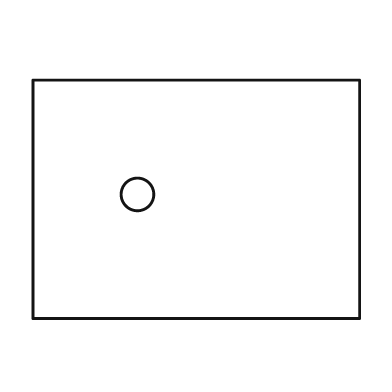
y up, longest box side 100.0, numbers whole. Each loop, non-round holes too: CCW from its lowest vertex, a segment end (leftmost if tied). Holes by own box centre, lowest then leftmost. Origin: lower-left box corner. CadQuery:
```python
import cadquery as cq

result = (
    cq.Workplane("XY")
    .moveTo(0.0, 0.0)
    .lineTo(100.0, 0.0)
    .lineTo(100.0, 73.0)
    .lineTo(0.0, 73.0)
    .close()
    .moveTo(32.0, 38.0)
    .circle(5.0)
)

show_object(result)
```